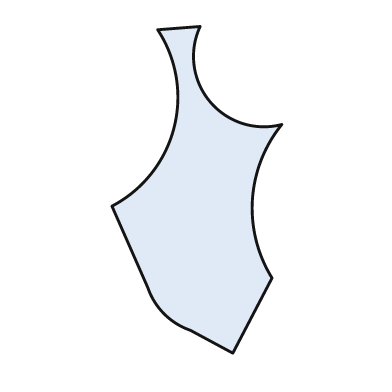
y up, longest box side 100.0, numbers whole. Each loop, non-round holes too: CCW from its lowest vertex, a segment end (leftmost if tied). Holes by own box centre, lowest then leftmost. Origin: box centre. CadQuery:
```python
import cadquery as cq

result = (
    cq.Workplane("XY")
    .moveTo(11.0, -50.0)
    .lineTo(23.0, -27.0)
    .threePointArc((17.0, -3.0), (26.0, 20.0))
    .threePointArc((4.0, 27.0), (1.0, 50.0))
    .lineTo(-12.0, 49.0)
    .threePointArc((-7.0, 19.0), (-26.0, -5.0))
    .lineTo(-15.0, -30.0)
    .threePointArc((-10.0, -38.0), (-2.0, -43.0))
    .close()
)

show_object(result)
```